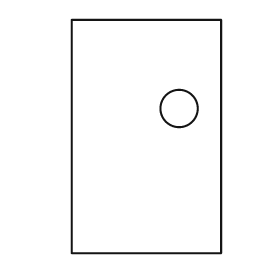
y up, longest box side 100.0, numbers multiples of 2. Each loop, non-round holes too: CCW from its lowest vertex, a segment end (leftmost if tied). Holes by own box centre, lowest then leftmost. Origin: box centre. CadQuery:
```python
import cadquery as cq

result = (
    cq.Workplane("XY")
    .moveTo(-32.0, -50.0)
    .lineTo(32.0, -50.0)
    .lineTo(32.0, 50.0)
    .lineTo(-32.0, 50.0)
    .close()
    .moveTo(14.0, 12.0)
    .circle(8.0)
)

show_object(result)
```